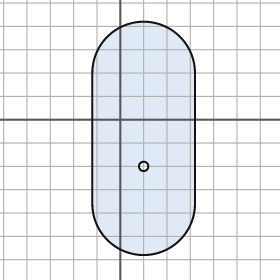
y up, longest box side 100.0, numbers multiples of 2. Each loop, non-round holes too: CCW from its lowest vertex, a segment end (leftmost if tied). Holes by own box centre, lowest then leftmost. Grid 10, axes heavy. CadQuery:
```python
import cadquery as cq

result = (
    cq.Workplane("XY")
    .moveTo(-12.0, -36.0)
    .threePointArc((10.0, -58.0), (32.0, -36.0))
    .lineTo(32.0, 20.0)
    .threePointArc((10.0, 42.0), (-12.0, 20.0))
    .close()
    .moveTo(10.0, -20.0)
    .circle(2.0)
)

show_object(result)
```